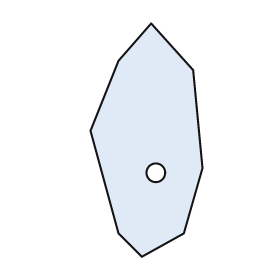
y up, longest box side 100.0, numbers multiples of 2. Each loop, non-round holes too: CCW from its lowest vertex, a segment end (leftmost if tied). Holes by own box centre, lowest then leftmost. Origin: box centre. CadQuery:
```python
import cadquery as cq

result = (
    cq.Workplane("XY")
    .moveTo(-2.0, -50.0)
    .lineTo(16.0, -40.0)
    .lineTo(24.0, -12.0)
    .lineTo(20.0, 30.0)
    .lineTo(2.0, 50.0)
    .lineTo(-12.0, 34.0)
    .lineTo(-24.0, 4.0)
    .lineTo(-12.0, -40.0)
    .close()
    .moveTo(4.0, -14.0)
    .circle(4.0)
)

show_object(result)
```